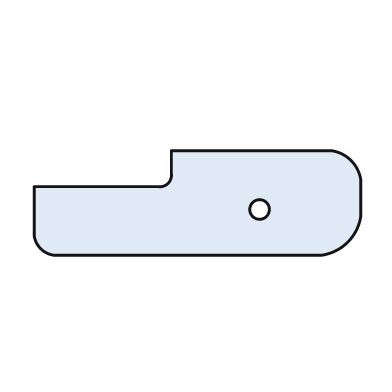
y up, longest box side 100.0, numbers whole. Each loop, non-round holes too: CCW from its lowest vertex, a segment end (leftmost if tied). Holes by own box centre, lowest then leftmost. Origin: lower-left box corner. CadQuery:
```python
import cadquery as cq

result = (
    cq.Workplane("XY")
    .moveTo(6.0, 0.0)
    .lineTo(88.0, 0.0)
    .threePointArc((96.0, 4.0), (100.0, 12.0))
    .lineTo(100.0, 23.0)
    .threePointArc((97.0, 29.0), (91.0, 32.0))
    .lineTo(42.0, 32.0)
    .lineTo(42.0, 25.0)
    .threePointArc((41.0, 22.0), (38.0, 21.0))
    .lineTo(0.0, 21.0)
    .lineTo(0.0, 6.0)
    .threePointArc((2.0, 2.0), (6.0, 0.0))
    .close()
    .moveTo(69.0, 14.0)
    .circle(3.0)
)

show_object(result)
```